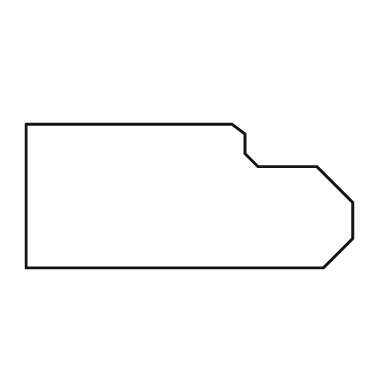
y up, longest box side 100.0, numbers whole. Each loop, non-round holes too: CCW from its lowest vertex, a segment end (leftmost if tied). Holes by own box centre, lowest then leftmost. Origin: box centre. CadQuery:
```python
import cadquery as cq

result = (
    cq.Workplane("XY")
    .moveTo(-50.0, -22.0)
    .lineTo(41.0, -22.0)
    .lineTo(50.0, -13.0)
    .lineTo(50.0, -2.0)
    .lineTo(39.0, 9.0)
    .lineTo(21.0, 9.0)
    .lineTo(17.0, 13.0)
    .lineTo(17.0, 19.0)
    .lineTo(13.0, 22.0)
    .lineTo(-50.0, 22.0)
    .close()
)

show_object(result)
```